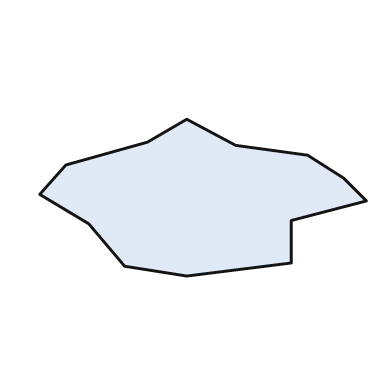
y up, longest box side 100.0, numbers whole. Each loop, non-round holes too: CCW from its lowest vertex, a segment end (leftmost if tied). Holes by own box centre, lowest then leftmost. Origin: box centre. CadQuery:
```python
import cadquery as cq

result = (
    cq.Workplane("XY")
    .moveTo(-5.0, -24.0)
    .lineTo(27.0, -20.0)
    .lineTo(27.0, -7.0)
    .lineTo(50.0, -1.0)
    .lineTo(43.0, 6.0)
    .lineTo(32.0, 13.0)
    .lineTo(10.0, 16.0)
    .lineTo(-5.0, 24.0)
    .lineTo(-17.0, 17.0)
    .lineTo(-42.0, 10.0)
    .lineTo(-50.0, 1.0)
    .lineTo(-35.0, -8.0)
    .lineTo(-24.0, -21.0)
    .close()
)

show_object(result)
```